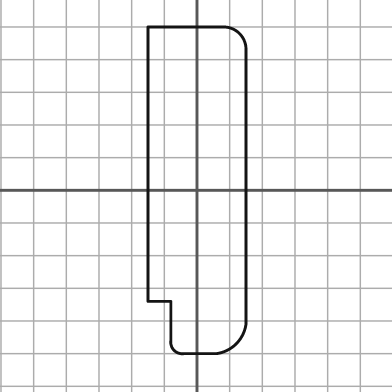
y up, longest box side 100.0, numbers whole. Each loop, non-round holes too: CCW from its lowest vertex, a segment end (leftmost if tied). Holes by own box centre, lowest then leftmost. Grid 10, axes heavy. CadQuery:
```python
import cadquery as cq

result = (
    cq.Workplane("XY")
    .moveTo(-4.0, -50.0)
    .lineTo(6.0, -50.0)
    .threePointArc((12.0, -47.0), (15.0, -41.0))
    .lineTo(15.0, 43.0)
    .threePointArc((13.0, 48.0), (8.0, 50.0))
    .lineTo(-15.0, 50.0)
    .lineTo(-15.0, -34.0)
    .lineTo(-8.0, -34.0)
    .lineTo(-8.0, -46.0)
    .threePointArc((-7.0, -49.0), (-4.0, -50.0))
    .close()
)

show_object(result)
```